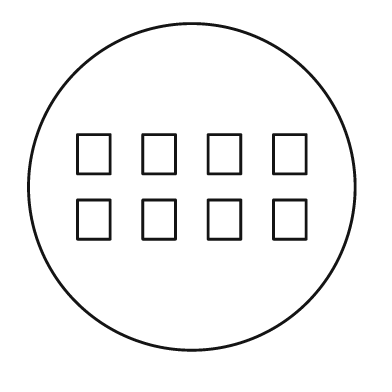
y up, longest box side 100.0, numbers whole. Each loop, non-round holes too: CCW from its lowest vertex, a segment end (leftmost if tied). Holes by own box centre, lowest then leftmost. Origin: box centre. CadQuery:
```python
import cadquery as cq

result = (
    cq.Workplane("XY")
    .moveTo(0.0, 0.0)
    .circle(50.0)
    .moveTo(-35.0, -16.0)
    .lineTo(-25.0, -16.0)
    .lineTo(-25.0, -4.0)
    .lineTo(-35.0, -4.0)
    .close()
    .moveTo(-15.0, -16.0)
    .lineTo(-5.0, -16.0)
    .lineTo(-5.0, -4.0)
    .lineTo(-15.0, -4.0)
    .close()
    .moveTo(5.0, -16.0)
    .lineTo(15.0, -16.0)
    .lineTo(15.0, -4.0)
    .lineTo(5.0, -4.0)
    .close()
    .moveTo(25.0, -16.0)
    .lineTo(35.0, -16.0)
    .lineTo(35.0, -4.0)
    .lineTo(25.0, -4.0)
    .close()
    .moveTo(-35.0, 4.0)
    .lineTo(-25.0, 4.0)
    .lineTo(-25.0, 16.0)
    .lineTo(-35.0, 16.0)
    .close()
    .moveTo(-15.0, 4.0)
    .lineTo(-5.0, 4.0)
    .lineTo(-5.0, 16.0)
    .lineTo(-15.0, 16.0)
    .close()
    .moveTo(5.0, 4.0)
    .lineTo(15.0, 4.0)
    .lineTo(15.0, 16.0)
    .lineTo(5.0, 16.0)
    .close()
    .moveTo(25.0, 4.0)
    .lineTo(35.0, 4.0)
    .lineTo(35.0, 16.0)
    .lineTo(25.0, 16.0)
    .close()
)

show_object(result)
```